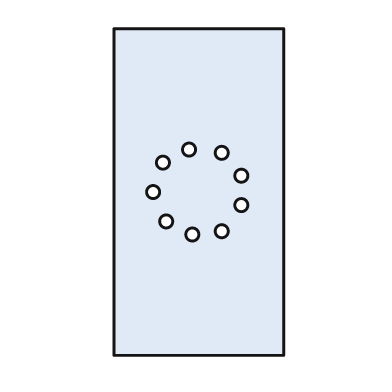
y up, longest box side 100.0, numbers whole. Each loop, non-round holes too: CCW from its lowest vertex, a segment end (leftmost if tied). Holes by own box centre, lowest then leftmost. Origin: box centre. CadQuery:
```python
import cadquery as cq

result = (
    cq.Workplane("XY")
    .moveTo(-26.0, -50.0)
    .lineTo(26.0, -50.0)
    .lineTo(26.0, 50.0)
    .lineTo(-26.0, 50.0)
    .close()
    .moveTo(-2.0, -13.0)
    .circle(2.0)
    .moveTo(7.0, -12.0)
    .circle(2.0)
    .moveTo(-10.0, -9.0)
    .circle(2.0)
    .moveTo(13.0, -4.0)
    .circle(2.0)
    .moveTo(-14.0, 0.0)
    .circle(2.0)
    .moveTo(13.0, 5.0)
    .circle(2.0)
    .moveTo(-11.0, 9.0)
    .circle(2.0)
    .moveTo(7.0, 12.0)
    .circle(2.0)
    .moveTo(-3.0, 13.0)
    .circle(2.0)
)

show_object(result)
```